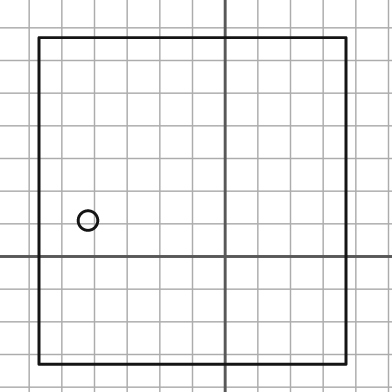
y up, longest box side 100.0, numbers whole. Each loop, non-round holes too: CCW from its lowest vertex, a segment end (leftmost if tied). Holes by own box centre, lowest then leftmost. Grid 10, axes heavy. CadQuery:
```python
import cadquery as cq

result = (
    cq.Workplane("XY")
    .moveTo(-57.0, -33.0)
    .lineTo(37.0, -33.0)
    .lineTo(37.0, 67.0)
    .lineTo(-57.0, 67.0)
    .close()
    .moveTo(-42.0, 11.0)
    .circle(3.0)
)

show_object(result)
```